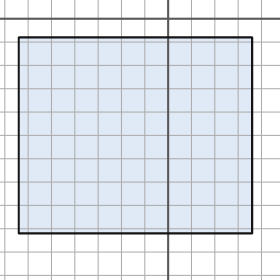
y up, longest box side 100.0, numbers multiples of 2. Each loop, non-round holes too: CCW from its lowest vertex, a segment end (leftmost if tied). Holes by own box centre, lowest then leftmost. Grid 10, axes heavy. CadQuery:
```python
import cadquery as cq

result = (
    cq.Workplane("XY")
    .moveTo(-64.0, -92.0)
    .lineTo(36.0, -92.0)
    .lineTo(36.0, -8.0)
    .lineTo(-64.0, -8.0)
    .close()
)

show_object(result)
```